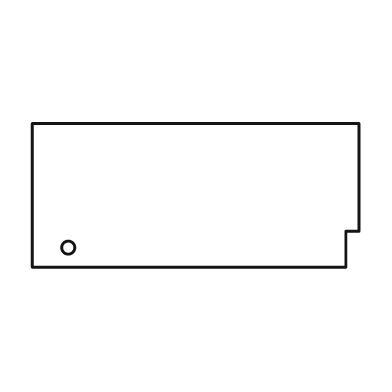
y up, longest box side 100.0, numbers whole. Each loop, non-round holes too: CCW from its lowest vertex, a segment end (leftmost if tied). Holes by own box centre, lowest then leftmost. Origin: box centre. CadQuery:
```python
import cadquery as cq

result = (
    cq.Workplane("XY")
    .moveTo(-50.0, -22.0)
    .lineTo(46.0, -22.0)
    .lineTo(46.0, -11.0)
    .lineTo(50.0, -11.0)
    .lineTo(50.0, 22.0)
    .lineTo(-50.0, 22.0)
    .close()
    .moveTo(-39.0, -16.0)
    .circle(2.0)
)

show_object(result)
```